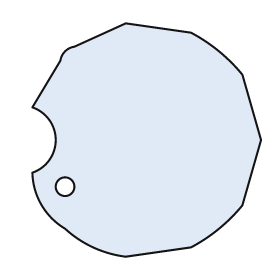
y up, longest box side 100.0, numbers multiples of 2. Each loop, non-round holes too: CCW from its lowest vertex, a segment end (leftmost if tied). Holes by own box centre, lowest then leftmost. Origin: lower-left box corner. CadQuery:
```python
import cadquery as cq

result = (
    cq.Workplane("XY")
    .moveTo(40.0, 0.0)
    .lineTo(68.0, 4.0)
    .threePointArc((80.0, 12.0), (90.0, 22.0))
    .lineTo(98.0, 50.0)
    .lineTo(90.0, 78.0)
    .threePointArc((80.0, 88.0), (68.0, 96.0))
    .lineTo(40.0, 100.0)
    .lineTo(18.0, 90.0)
    .threePointArc((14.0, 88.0), (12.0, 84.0))
    .lineTo(0.0, 64.0)
    .threePointArc((10.0, 50.0), (0.0, 36.0))
    .threePointArc((4.0, 22.0), (14.0, 12.0))
    .threePointArc((26.0, 4.0), (40.0, 0.0))
    .close()
    .moveTo(14.0, 30.0)
    .circle(4.0)
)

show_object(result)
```